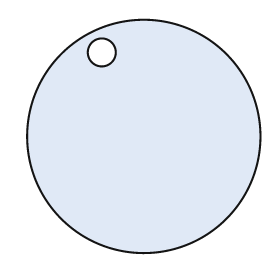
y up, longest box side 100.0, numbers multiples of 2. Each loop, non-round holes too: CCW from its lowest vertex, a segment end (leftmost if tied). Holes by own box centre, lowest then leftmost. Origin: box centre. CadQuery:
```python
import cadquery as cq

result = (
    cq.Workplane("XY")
    .moveTo(0.0, 0.0)
    .circle(50.0)
    .moveTo(-18.0, 36.0)
    .circle(6.0)
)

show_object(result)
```